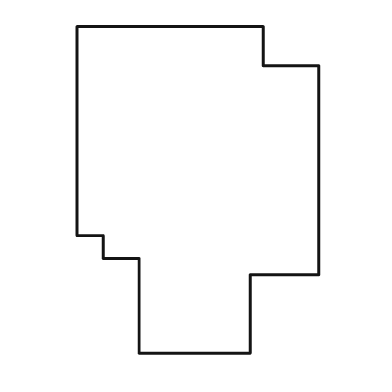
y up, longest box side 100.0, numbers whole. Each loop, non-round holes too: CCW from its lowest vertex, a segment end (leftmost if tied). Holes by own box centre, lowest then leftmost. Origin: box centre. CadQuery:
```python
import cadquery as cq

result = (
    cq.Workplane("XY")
    .moveTo(-18.0, -50.0)
    .lineTo(16.0, -50.0)
    .lineTo(16.0, -26.0)
    .lineTo(37.0, -26.0)
    .lineTo(37.0, 38.0)
    .lineTo(20.0, 38.0)
    .lineTo(20.0, 50.0)
    .lineTo(-37.0, 50.0)
    .lineTo(-37.0, -14.0)
    .lineTo(-29.0, -14.0)
    .lineTo(-29.0, -21.0)
    .lineTo(-18.0, -21.0)
    .close()
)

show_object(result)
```